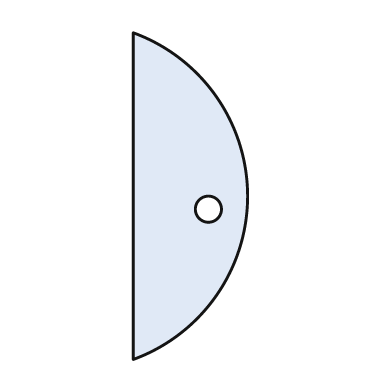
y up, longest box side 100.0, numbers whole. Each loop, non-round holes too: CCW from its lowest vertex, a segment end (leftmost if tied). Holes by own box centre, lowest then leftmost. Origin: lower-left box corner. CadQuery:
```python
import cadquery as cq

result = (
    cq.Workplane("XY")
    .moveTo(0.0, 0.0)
    .threePointArc((35.0, 50.0), (0.0, 100.0))
    .close()
    .moveTo(23.0, 46.0)
    .circle(4.0)
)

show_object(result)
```